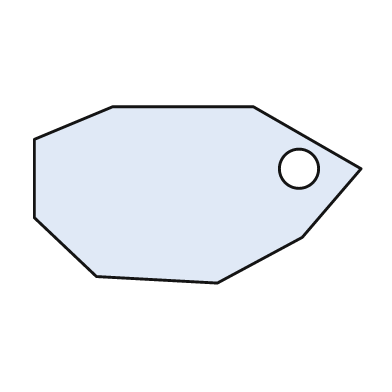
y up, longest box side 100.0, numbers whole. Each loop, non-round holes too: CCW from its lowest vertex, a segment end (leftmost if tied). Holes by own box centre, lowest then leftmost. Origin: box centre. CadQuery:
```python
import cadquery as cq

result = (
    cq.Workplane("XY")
    .moveTo(6.0, -27.0)
    .lineTo(32.0, -13.0)
    .lineTo(50.0, 8.0)
    .lineTo(17.0, 27.0)
    .lineTo(-26.0, 27.0)
    .lineTo(-50.0, 17.0)
    .lineTo(-50.0, -7.0)
    .lineTo(-31.0, -25.0)
    .close()
    .moveTo(31.0, 8.0)
    .circle(6.0)
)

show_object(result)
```